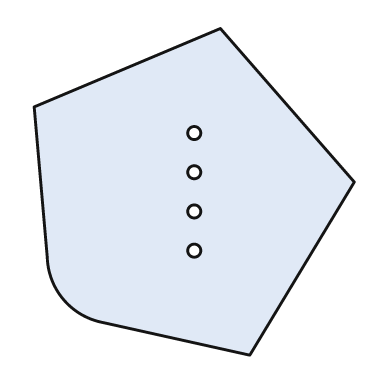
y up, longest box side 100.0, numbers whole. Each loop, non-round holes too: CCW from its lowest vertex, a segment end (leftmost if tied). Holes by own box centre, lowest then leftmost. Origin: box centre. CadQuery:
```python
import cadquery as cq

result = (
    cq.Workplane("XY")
    .moveTo(17.0, -50.0)
    .lineTo(49.0, 3.0)
    .lineTo(8.0, 50.0)
    .lineTo(-49.0, 26.0)
    .lineTo(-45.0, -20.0)
    .threePointArc((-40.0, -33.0), (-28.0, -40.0))
    .close()
    .moveTo(0.0, -18.0)
    .circle(2.0)
    .moveTo(0.0, -6.0)
    .circle(2.0)
    .moveTo(0.0, 6.0)
    .circle(2.0)
    .moveTo(0.0, 18.0)
    .circle(2.0)
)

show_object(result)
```